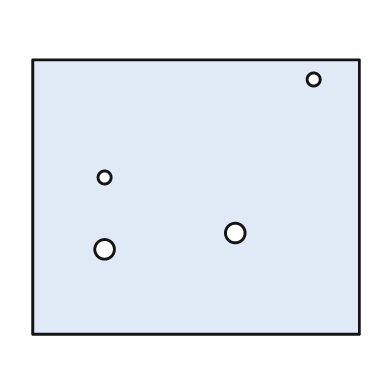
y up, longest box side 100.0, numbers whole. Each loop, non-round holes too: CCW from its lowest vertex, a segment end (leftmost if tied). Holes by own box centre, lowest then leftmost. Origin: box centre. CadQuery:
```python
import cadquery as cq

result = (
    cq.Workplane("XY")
    .moveTo(-50.0, -42.0)
    .lineTo(50.0, -42.0)
    .lineTo(50.0, 42.0)
    .lineTo(-50.0, 42.0)
    .close()
    .moveTo(-28.0, -16.0)
    .circle(3.0)
    .moveTo(12.0, -11.0)
    .circle(3.0)
    .moveTo(-28.0, 6.0)
    .circle(2.0)
    .moveTo(36.0, 36.0)
    .circle(2.0)
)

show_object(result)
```